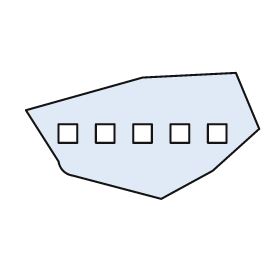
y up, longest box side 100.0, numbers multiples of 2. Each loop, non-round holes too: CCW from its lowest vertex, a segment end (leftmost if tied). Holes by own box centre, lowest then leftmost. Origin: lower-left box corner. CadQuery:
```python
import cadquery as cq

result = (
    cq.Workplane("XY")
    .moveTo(58.0, 0.0)
    .lineTo(80.0, 12.0)
    .lineTo(100.0, 30.0)
    .lineTo(90.0, 54.0)
    .lineTo(50.0, 52.0)
    .lineTo(0.0, 38.0)
    .lineTo(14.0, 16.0)
    .threePointArc((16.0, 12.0), (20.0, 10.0))
    .close()
    .moveTo(14.0, 24.0)
    .lineTo(22.0, 24.0)
    .lineTo(22.0, 32.0)
    .lineTo(14.0, 32.0)
    .close()
    .moveTo(30.0, 24.0)
    .lineTo(38.0, 24.0)
    .lineTo(38.0, 32.0)
    .lineTo(30.0, 32.0)
    .close()
    .moveTo(46.0, 24.0)
    .lineTo(54.0, 24.0)
    .lineTo(54.0, 32.0)
    .lineTo(46.0, 32.0)
    .close()
    .moveTo(62.0, 24.0)
    .lineTo(70.0, 24.0)
    .lineTo(70.0, 32.0)
    .lineTo(62.0, 32.0)
    .close()
    .moveTo(78.0, 24.0)
    .lineTo(86.0, 24.0)
    .lineTo(86.0, 32.0)
    .lineTo(78.0, 32.0)
    .close()
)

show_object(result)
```